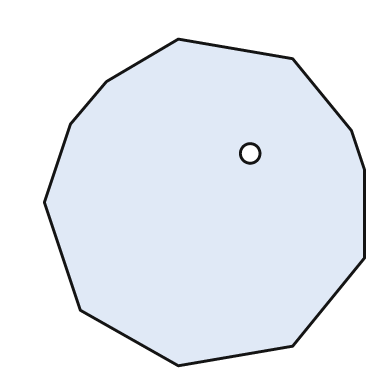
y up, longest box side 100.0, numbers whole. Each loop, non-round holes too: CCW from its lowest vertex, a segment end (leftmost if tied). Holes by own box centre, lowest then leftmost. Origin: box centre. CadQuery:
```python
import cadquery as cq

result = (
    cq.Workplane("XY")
    .moveTo(-8.0, -50.0)
    .lineTo(27.0, -44.0)
    .lineTo(49.0, -17.0)
    .lineTo(49.0, 10.0)
    .lineTo(45.0, 22.0)
    .lineTo(27.0, 44.0)
    .lineTo(-8.0, 50.0)
    .lineTo(-30.0, 37.0)
    .lineTo(-41.0, 24.0)
    .lineTo(-49.0, 0.0)
    .lineTo(-38.0, -33.0)
    .close()
    .moveTo(14.0, 15.0)
    .circle(3.0)
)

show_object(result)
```